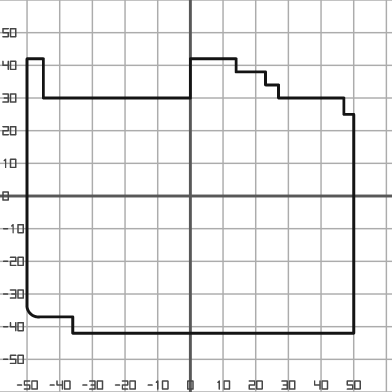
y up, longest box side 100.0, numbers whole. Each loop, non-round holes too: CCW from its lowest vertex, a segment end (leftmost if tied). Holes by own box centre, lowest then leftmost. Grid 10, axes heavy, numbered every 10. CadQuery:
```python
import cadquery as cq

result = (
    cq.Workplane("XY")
    .moveTo(-36.0, -42.0)
    .lineTo(50.0, -42.0)
    .lineTo(50.0, 25.0)
    .lineTo(47.0, 25.0)
    .lineTo(47.0, 30.0)
    .lineTo(27.0, 30.0)
    .lineTo(27.0, 34.0)
    .lineTo(23.0, 34.0)
    .lineTo(23.0, 38.0)
    .lineTo(14.0, 38.0)
    .lineTo(14.0, 42.0)
    .lineTo(0.0, 42.0)
    .lineTo(0.0, 30.0)
    .lineTo(-45.0, 30.0)
    .lineTo(-45.0, 42.0)
    .lineTo(-50.0, 42.0)
    .lineTo(-50.0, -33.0)
    .threePointArc((-49.0, -36.0), (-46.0, -37.0))
    .lineTo(-36.0, -37.0)
    .close()
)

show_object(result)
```